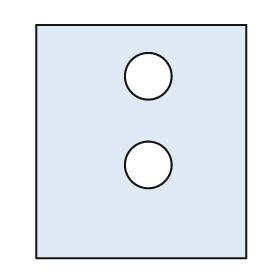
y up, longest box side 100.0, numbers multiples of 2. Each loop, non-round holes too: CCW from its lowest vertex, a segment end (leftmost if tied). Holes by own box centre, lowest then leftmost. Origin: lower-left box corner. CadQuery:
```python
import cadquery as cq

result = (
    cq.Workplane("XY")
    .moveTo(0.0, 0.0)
    .lineTo(90.0, 0.0)
    .lineTo(90.0, 100.0)
    .lineTo(0.0, 100.0)
    .close()
    .moveTo(48.0, 40.0)
    .circle(10.0)
    .moveTo(48.0, 78.0)
    .circle(10.0)
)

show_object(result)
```